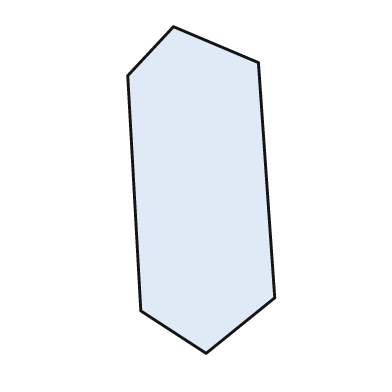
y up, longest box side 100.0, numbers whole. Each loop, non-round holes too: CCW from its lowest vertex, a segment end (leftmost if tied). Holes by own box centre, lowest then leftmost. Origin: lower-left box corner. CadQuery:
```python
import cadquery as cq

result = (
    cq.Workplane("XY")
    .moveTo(24.0, 0.0)
    .lineTo(45.0, 17.0)
    .lineTo(40.0, 89.0)
    .lineTo(14.0, 100.0)
    .lineTo(0.0, 85.0)
    .lineTo(4.0, 13.0)
    .close()
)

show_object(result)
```